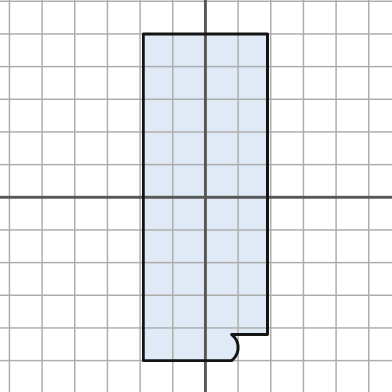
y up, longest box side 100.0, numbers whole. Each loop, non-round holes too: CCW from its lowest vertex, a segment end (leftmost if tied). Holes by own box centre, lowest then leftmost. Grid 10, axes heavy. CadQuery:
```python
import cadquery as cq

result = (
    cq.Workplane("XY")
    .moveTo(-19.0, -50.0)
    .lineTo(8.0, -50.0)
    .threePointArc((10.0, -46.0), (8.0, -42.0))
    .lineTo(19.0, -42.0)
    .lineTo(19.0, 50.0)
    .lineTo(-19.0, 50.0)
    .close()
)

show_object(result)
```